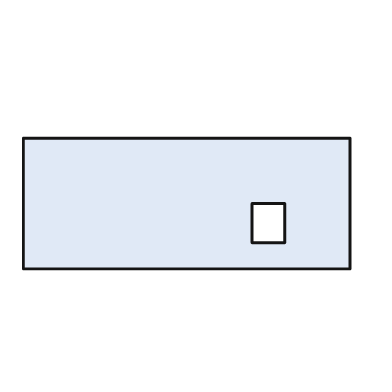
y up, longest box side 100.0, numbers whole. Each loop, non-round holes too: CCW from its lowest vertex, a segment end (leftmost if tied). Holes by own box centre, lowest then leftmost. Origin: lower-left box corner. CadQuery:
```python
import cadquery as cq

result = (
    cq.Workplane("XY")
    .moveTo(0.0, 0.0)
    .lineTo(100.0, 0.0)
    .lineTo(100.0, 40.0)
    .lineTo(0.0, 40.0)
    .close()
    .moveTo(70.0, 8.0)
    .lineTo(80.0, 8.0)
    .lineTo(80.0, 20.0)
    .lineTo(70.0, 20.0)
    .close()
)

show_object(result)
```